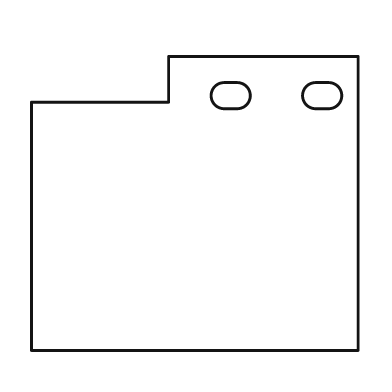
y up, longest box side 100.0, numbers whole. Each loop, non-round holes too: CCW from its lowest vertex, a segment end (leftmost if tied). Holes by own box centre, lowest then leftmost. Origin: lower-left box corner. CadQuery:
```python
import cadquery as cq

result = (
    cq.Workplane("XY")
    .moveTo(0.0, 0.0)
    .lineTo(100.0, 0.0)
    .lineTo(100.0, 90.0)
    .lineTo(42.0, 90.0)
    .lineTo(42.0, 76.0)
    .lineTo(0.0, 76.0)
    .close()
    .moveTo(59.0, 74.0)
    .lineTo(63.0, 74.0)
    .threePointArc((67.0, 78.0), (63.0, 82.0))
    .lineTo(59.0, 82.0)
    .threePointArc((55.0, 78.0), (59.0, 74.0))
    .close()
    .moveTo(87.0, 74.0)
    .lineTo(91.0, 74.0)
    .threePointArc((95.0, 78.0), (91.0, 82.0))
    .lineTo(87.0, 82.0)
    .threePointArc((83.0, 78.0), (87.0, 74.0))
    .close()
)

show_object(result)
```